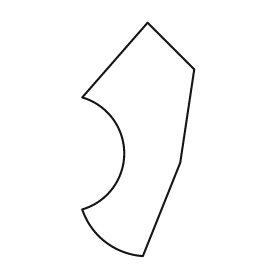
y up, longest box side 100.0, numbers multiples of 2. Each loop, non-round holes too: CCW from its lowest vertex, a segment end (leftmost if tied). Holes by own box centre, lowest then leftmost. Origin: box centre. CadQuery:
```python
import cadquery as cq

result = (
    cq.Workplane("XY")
    .moveTo(2.0, -50.0)
    .lineTo(18.0, -10.0)
    .lineTo(24.0, 30.0)
    .lineTo(4.0, 50.0)
    .lineTo(-24.0, 18.0)
    .threePointArc((-6.0, -6.0), (-24.0, -30.0))
    .threePointArc((-14.0, -44.0), (2.0, -50.0))
    .close()
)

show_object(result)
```